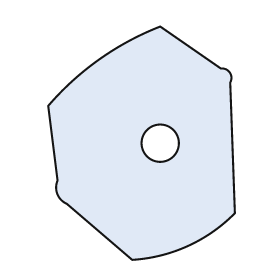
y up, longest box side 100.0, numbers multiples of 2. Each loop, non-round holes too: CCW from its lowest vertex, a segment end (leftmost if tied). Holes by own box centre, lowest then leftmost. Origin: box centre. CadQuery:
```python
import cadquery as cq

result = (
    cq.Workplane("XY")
    .moveTo(-4.0, -50.0)
    .threePointArc((20.0, -44.0), (40.0, -30.0))
    .lineTo(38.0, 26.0)
    .threePointArc((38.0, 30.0), (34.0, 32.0))
    .lineTo(8.0, 50.0)
    .threePointArc((-18.0, 36.0), (-40.0, 16.0))
    .lineTo(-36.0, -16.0)
    .threePointArc((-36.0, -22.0), (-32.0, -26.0))
    .close()
    .moveTo(8.0, 0.0)
    .circle(8.0)
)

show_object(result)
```